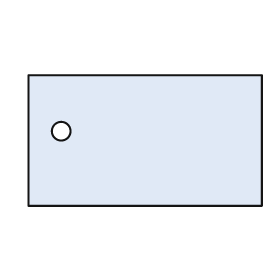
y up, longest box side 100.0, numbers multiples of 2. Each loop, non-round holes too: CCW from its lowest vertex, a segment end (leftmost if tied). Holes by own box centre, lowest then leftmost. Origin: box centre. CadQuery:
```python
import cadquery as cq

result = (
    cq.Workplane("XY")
    .moveTo(-50.0, -28.0)
    .lineTo(50.0, -28.0)
    .lineTo(50.0, 28.0)
    .lineTo(-50.0, 28.0)
    .close()
    .moveTo(-36.0, 4.0)
    .circle(4.0)
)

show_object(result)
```